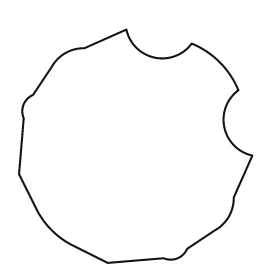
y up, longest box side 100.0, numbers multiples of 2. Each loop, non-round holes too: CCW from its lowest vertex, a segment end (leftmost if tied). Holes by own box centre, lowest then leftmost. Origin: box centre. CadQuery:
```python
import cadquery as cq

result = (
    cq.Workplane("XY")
    .moveTo(-12.0, -50.0)
    .lineTo(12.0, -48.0)
    .threePointArc((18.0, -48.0), (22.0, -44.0))
    .lineTo(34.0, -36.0)
    .threePointArc((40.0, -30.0), (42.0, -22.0))
    .lineTo(50.0, -4.0)
    .threePointArc((38.0, 8.0), (44.0, 24.0))
    .threePointArc((36.0, 36.0), (24.0, 44.0))
    .threePointArc((8.0, 38.0), (-4.0, 50.0))
    .lineTo(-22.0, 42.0)
    .threePointArc((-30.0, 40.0), (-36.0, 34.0))
    .lineTo(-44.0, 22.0)
    .threePointArc((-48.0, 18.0), (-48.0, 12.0))
    .lineTo(-50.0, -12.0)
    .lineTo(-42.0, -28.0)
    .threePointArc((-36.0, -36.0), (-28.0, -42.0))
    .close()
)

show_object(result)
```